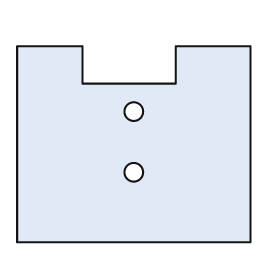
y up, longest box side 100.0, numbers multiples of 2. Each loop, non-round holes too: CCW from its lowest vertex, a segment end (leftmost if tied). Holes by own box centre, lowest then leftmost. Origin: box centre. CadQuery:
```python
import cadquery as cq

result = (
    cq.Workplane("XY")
    .moveTo(-50.0, -42.0)
    .lineTo(50.0, -42.0)
    .lineTo(50.0, 42.0)
    .lineTo(18.0, 42.0)
    .lineTo(18.0, 26.0)
    .lineTo(-22.0, 26.0)
    .lineTo(-22.0, 42.0)
    .lineTo(-50.0, 42.0)
    .close()
    .moveTo(0.0, -12.0)
    .circle(4.0)
    .moveTo(0.0, 14.0)
    .circle(4.0)
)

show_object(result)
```